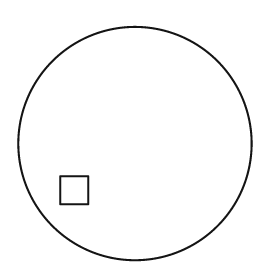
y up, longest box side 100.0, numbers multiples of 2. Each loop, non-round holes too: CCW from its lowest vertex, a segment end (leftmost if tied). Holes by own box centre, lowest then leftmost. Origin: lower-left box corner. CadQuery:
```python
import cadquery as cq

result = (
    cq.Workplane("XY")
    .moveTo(50.0, 50.0)
    .circle(50.0)
    .moveTo(18.0, 24.0)
    .lineTo(30.0, 24.0)
    .lineTo(30.0, 36.0)
    .lineTo(18.0, 36.0)
    .close()
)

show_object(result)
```